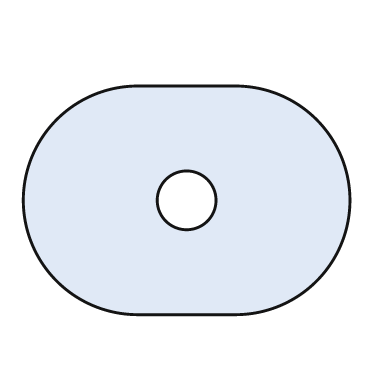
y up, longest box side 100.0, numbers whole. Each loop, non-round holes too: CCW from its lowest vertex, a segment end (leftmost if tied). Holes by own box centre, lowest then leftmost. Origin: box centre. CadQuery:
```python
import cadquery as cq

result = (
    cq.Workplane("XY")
    .moveTo(-15.0, -35.0)
    .lineTo(15.0, -35.0)
    .threePointArc((50.0, 0.0), (15.0, 35.0))
    .lineTo(-15.0, 35.0)
    .threePointArc((-50.0, 0.0), (-15.0, -35.0))
    .close()
    .moveTo(0.0, 0.0)
    .circle(9.0)
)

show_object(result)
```